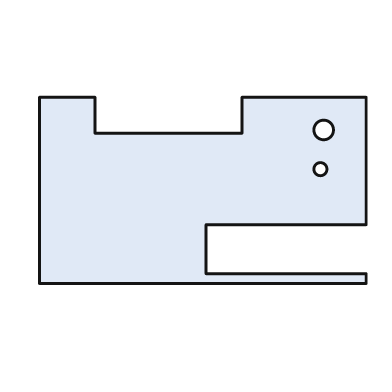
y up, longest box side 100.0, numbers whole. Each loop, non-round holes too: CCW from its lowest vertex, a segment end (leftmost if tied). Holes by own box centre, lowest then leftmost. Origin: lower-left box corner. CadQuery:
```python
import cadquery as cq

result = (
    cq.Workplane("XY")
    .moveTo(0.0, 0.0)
    .lineTo(100.0, 0.0)
    .lineTo(100.0, 3.0)
    .lineTo(51.0, 3.0)
    .lineTo(51.0, 18.0)
    .lineTo(100.0, 18.0)
    .lineTo(100.0, 57.0)
    .lineTo(62.0, 57.0)
    .lineTo(62.0, 46.0)
    .lineTo(17.0, 46.0)
    .lineTo(17.0, 57.0)
    .lineTo(0.0, 57.0)
    .close()
    .moveTo(86.0, 35.0)
    .circle(2.0)
    .moveTo(87.0, 47.0)
    .circle(3.0)
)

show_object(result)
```